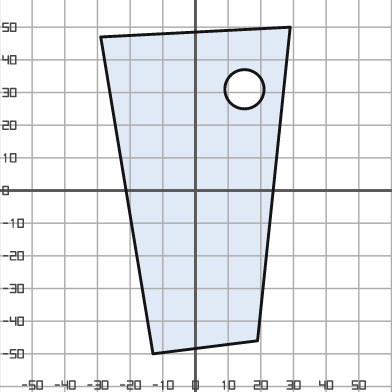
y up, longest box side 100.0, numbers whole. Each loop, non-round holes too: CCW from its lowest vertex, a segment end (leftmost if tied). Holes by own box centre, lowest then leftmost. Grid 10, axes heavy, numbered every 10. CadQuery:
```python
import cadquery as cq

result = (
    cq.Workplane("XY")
    .moveTo(-13.0, -50.0)
    .lineTo(19.0, -46.0)
    .lineTo(29.0, 50.0)
    .lineTo(-29.0, 47.0)
    .close()
    .moveTo(15.0, 31.0)
    .circle(6.0)
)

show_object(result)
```